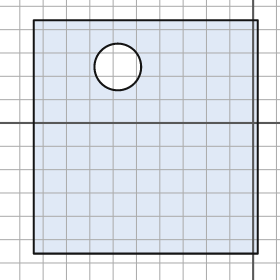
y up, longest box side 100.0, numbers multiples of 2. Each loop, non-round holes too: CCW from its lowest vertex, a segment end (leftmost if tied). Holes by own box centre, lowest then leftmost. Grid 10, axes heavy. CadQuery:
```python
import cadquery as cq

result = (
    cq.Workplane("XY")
    .moveTo(-94.0, -56.0)
    .lineTo(2.0, -56.0)
    .lineTo(2.0, 44.0)
    .lineTo(-94.0, 44.0)
    .close()
    .moveTo(-58.0, 24.0)
    .circle(10.0)
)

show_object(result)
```